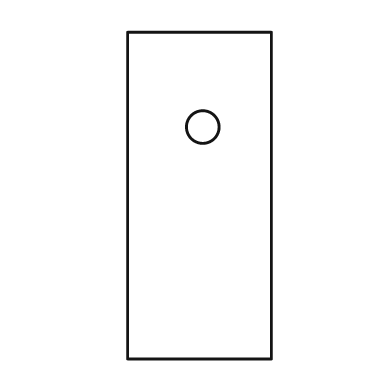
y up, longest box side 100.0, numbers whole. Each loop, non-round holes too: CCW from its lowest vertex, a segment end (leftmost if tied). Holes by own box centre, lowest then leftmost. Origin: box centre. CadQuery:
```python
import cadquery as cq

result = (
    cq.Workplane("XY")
    .moveTo(-22.0, -50.0)
    .lineTo(22.0, -50.0)
    .lineTo(22.0, 50.0)
    .lineTo(-22.0, 50.0)
    .close()
    .moveTo(1.0, 21.0)
    .circle(5.0)
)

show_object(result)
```